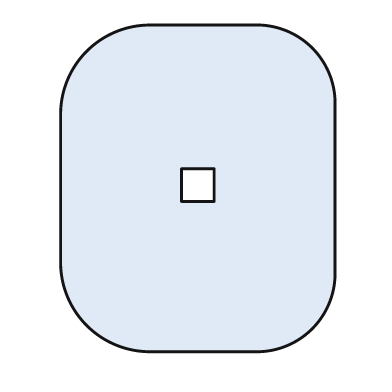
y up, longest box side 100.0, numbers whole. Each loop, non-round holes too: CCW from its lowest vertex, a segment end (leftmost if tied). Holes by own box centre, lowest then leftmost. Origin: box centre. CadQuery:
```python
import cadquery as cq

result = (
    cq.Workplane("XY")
    .moveTo(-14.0, -50.0)
    .lineTo(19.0, -50.0)
    .threePointArc((35.0, -43.0), (42.0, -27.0))
    .lineTo(42.0, 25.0)
    .threePointArc((35.0, 43.0), (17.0, 50.0))
    .lineTo(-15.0, 50.0)
    .threePointArc((-34.0, 42.0), (-42.0, 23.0))
    .lineTo(-42.0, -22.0)
    .threePointArc((-34.0, -42.0), (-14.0, -50.0))
    .close()
    .moveTo(-5.0, -4.0)
    .lineTo(5.0, -4.0)
    .lineTo(5.0, 6.0)
    .lineTo(-5.0, 6.0)
    .close()
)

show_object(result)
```